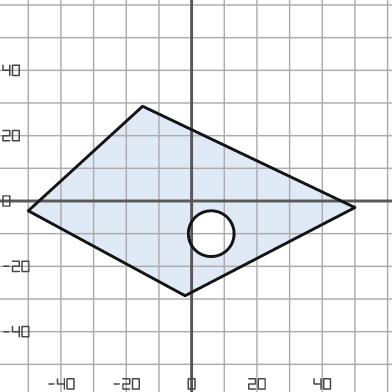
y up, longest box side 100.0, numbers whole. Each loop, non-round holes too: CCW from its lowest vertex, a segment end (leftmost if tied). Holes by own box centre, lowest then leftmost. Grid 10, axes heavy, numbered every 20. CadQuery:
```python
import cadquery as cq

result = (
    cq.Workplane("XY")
    .moveTo(-2.0, -29.0)
    .lineTo(50.0, -2.0)
    .lineTo(-15.0, 29.0)
    .lineTo(-50.0, -3.0)
    .close()
    .moveTo(6.0, -10.0)
    .circle(7.0)
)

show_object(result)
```